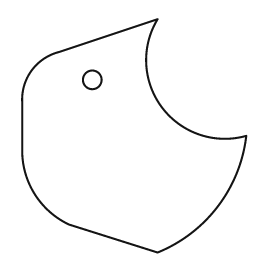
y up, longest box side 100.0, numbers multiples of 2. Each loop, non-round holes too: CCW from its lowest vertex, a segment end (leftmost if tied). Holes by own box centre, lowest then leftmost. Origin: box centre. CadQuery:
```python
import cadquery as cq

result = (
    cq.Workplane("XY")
    .moveTo(10.0, -50.0)
    .threePointArc((36.0, -30.0), (48.0, 0.0))
    .threePointArc((12.0, 12.0), (10.0, 50.0))
    .lineTo(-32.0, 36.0)
    .threePointArc((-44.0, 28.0), (-48.0, 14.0))
    .lineTo(-48.0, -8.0)
    .threePointArc((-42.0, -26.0), (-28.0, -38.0))
    .close()
    .moveTo(-18.0, 24.0)
    .circle(4.0)
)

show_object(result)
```